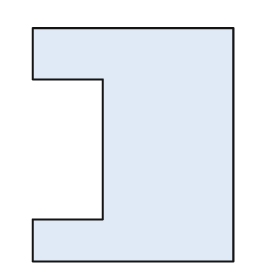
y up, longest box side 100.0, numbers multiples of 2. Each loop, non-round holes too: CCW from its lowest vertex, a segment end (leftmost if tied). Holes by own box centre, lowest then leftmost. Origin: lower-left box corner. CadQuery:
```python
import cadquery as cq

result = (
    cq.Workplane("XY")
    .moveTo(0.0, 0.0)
    .lineTo(86.0, 0.0)
    .lineTo(86.0, 100.0)
    .lineTo(0.0, 100.0)
    .lineTo(0.0, 78.0)
    .lineTo(30.0, 78.0)
    .lineTo(30.0, 18.0)
    .lineTo(0.0, 18.0)
    .close()
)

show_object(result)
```